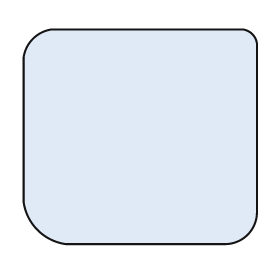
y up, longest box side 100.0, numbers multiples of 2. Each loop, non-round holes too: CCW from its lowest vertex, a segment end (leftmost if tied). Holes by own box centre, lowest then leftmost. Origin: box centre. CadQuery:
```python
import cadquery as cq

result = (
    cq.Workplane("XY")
    .moveTo(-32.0, -46.0)
    .lineTo(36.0, -46.0)
    .threePointArc((46.0, -42.0), (50.0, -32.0))
    .lineTo(50.0, 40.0)
    .threePointArc((48.0, 44.0), (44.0, 46.0))
    .lineTo(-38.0, 46.0)
    .threePointArc((-46.0, 42.0), (-50.0, 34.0))
    .lineTo(-50.0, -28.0)
    .threePointArc((-44.0, -40.0), (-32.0, -46.0))
    .close()
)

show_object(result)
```